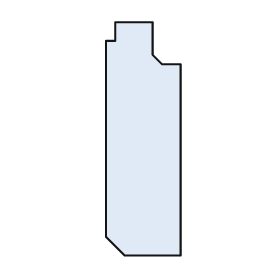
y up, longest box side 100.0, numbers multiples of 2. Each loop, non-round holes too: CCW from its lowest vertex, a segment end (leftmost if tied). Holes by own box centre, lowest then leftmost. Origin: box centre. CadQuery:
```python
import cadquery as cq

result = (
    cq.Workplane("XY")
    .moveTo(-8.0, -50.0)
    .lineTo(16.0, -50.0)
    .lineTo(16.0, 32.0)
    .lineTo(8.0, 32.0)
    .lineTo(4.0, 36.0)
    .lineTo(4.0, 50.0)
    .lineTo(-12.0, 50.0)
    .lineTo(-12.0, 42.0)
    .lineTo(-16.0, 42.0)
    .lineTo(-16.0, -42.0)
    .close()
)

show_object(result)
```